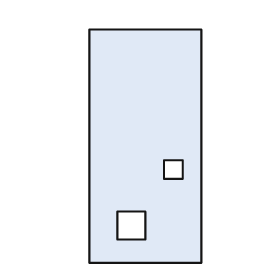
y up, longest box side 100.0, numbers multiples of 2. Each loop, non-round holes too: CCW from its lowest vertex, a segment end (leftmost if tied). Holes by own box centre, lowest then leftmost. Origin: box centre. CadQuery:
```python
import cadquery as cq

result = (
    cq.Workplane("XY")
    .moveTo(-24.0, -50.0)
    .lineTo(24.0, -50.0)
    .lineTo(24.0, 50.0)
    .lineTo(-24.0, 50.0)
    .close()
    .moveTo(-12.0, -40.0)
    .lineTo(0.0, -40.0)
    .lineTo(0.0, -28.0)
    .lineTo(-12.0, -28.0)
    .close()
    .moveTo(8.0, -14.0)
    .lineTo(16.0, -14.0)
    .lineTo(16.0, -6.0)
    .lineTo(8.0, -6.0)
    .close()
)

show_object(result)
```